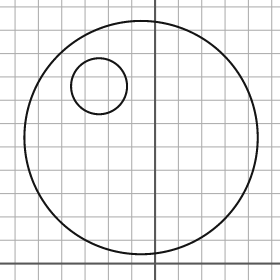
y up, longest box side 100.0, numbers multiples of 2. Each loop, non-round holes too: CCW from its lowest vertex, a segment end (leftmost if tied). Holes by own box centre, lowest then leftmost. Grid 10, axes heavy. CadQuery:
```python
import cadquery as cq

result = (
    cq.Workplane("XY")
    .moveTo(-6.0, 54.0)
    .circle(50.0)
    .moveTo(-24.0, 76.0)
    .circle(12.0)
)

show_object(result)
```